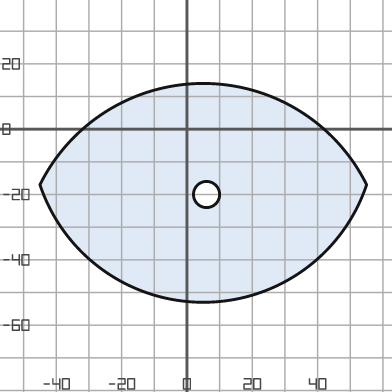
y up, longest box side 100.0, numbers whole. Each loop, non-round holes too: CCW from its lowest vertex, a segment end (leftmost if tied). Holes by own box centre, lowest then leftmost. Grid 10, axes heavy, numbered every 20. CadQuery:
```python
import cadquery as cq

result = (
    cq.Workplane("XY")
    .moveTo(-45.0, -17.0)
    .threePointArc((5.0, -53.0), (55.0, -17.0))
    .threePointArc((5.0, 14.0), (-45.0, -17.0))
    .close()
    .moveTo(6.0, -20.0)
    .circle(4.0)
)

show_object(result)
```